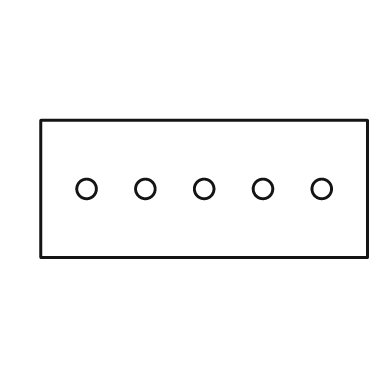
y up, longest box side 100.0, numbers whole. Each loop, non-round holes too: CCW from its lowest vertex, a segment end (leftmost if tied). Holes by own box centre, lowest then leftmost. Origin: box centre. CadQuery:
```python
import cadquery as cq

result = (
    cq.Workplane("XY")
    .moveTo(-50.0, -21.0)
    .lineTo(50.0, -21.0)
    .lineTo(50.0, 21.0)
    .lineTo(-50.0, 21.0)
    .close()
    .moveTo(-36.0, 0.0)
    .circle(3.0)
    .moveTo(-18.0, 0.0)
    .circle(3.0)
    .moveTo(0.0, 0.0)
    .circle(3.0)
    .moveTo(18.0, 0.0)
    .circle(3.0)
    .moveTo(36.0, 0.0)
    .circle(3.0)
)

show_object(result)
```